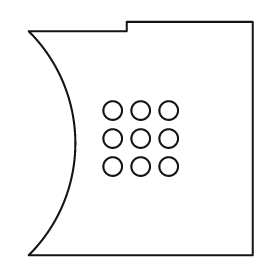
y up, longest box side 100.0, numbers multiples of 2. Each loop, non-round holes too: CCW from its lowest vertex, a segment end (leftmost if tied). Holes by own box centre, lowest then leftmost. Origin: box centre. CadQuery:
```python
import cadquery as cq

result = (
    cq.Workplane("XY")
    .moveTo(-48.0, -50.0)
    .lineTo(48.0, -50.0)
    .lineTo(48.0, 50.0)
    .lineTo(-6.0, 50.0)
    .lineTo(-6.0, 46.0)
    .lineTo(-48.0, 46.0)
    .threePointArc((-28.0, -2.0), (-48.0, -50.0))
    .close()
    .moveTo(-12.0, -12.0)
    .circle(4.0)
    .moveTo(0.0, -12.0)
    .circle(4.0)
    .moveTo(12.0, -12.0)
    .circle(4.0)
    .moveTo(-12.0, 0.0)
    .circle(4.0)
    .moveTo(0.0, 0.0)
    .circle(4.0)
    .moveTo(12.0, 0.0)
    .circle(4.0)
    .moveTo(-12.0, 12.0)
    .circle(4.0)
    .moveTo(0.0, 12.0)
    .circle(4.0)
    .moveTo(12.0, 12.0)
    .circle(4.0)
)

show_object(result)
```